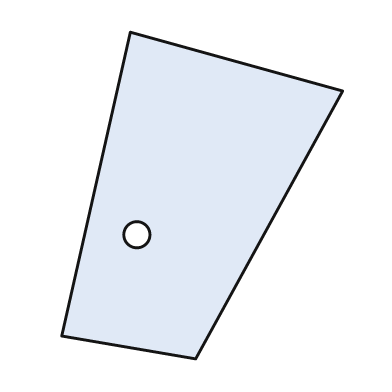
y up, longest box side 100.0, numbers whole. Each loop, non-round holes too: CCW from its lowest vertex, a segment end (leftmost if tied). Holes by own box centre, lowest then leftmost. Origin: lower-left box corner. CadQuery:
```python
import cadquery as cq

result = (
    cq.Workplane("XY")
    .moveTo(41.0, 0.0)
    .lineTo(86.0, 82.0)
    .lineTo(21.0, 100.0)
    .lineTo(0.0, 7.0)
    .close()
    .moveTo(23.0, 38.0)
    .circle(4.0)
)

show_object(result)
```